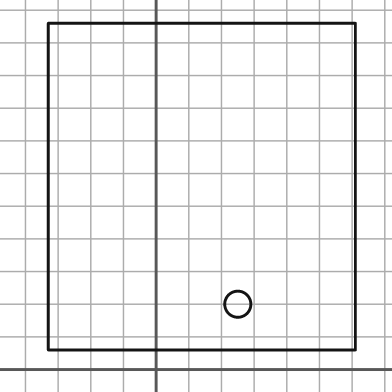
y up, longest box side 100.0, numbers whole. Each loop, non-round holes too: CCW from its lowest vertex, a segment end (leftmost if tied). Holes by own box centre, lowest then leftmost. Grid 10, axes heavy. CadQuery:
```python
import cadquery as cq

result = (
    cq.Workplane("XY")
    .moveTo(-33.0, 6.0)
    .lineTo(61.0, 6.0)
    .lineTo(61.0, 106.0)
    .lineTo(-33.0, 106.0)
    .close()
    .moveTo(25.0, 20.0)
    .circle(4.0)
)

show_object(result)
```